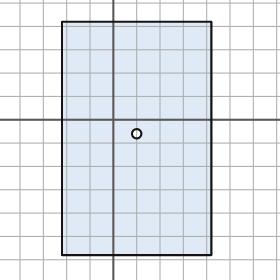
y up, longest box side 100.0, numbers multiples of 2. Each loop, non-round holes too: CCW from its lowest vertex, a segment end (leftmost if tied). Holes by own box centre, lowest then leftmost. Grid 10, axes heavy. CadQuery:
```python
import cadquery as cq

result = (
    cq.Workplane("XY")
    .moveTo(-22.0, -58.0)
    .lineTo(42.0, -58.0)
    .lineTo(42.0, 42.0)
    .lineTo(-22.0, 42.0)
    .close()
    .moveTo(10.0, -6.0)
    .circle(2.0)
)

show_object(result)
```